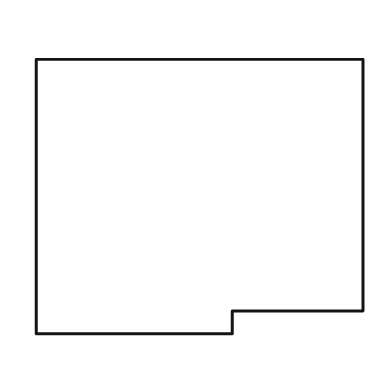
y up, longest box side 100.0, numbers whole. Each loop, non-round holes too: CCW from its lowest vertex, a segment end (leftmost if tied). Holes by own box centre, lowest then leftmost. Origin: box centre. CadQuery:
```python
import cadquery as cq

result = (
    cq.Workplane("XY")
    .moveTo(-50.0, -42.0)
    .lineTo(10.0, -42.0)
    .lineTo(10.0, -35.0)
    .lineTo(50.0, -35.0)
    .lineTo(50.0, 42.0)
    .lineTo(-50.0, 42.0)
    .close()
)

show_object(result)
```